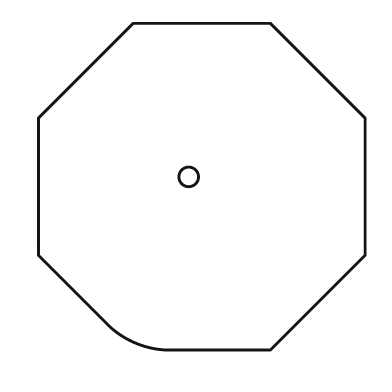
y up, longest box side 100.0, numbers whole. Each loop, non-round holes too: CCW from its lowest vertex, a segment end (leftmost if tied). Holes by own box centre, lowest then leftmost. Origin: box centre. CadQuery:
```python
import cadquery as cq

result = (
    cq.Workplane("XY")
    .moveTo(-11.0, -50.0)
    .lineTo(21.0, -50.0)
    .lineTo(50.0, -21.0)
    .lineTo(50.0, 21.0)
    .lineTo(21.0, 50.0)
    .lineTo(-21.0, 50.0)
    .lineTo(-50.0, 21.0)
    .lineTo(-50.0, -21.0)
    .lineTo(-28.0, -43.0)
    .threePointArc((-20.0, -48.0), (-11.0, -50.0))
    .close()
    .moveTo(-4.0, 3.0)
    .circle(3.0)
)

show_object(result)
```